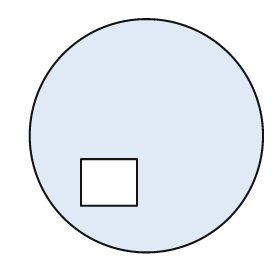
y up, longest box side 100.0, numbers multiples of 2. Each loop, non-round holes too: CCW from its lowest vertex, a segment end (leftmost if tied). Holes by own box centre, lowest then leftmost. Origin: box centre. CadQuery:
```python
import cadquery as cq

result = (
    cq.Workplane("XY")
    .moveTo(0.0, 0.0)
    .circle(50.0)
    .moveTo(-28.0, -30.0)
    .lineTo(-4.0, -30.0)
    .lineTo(-4.0, -10.0)
    .lineTo(-28.0, -10.0)
    .close()
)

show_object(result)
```